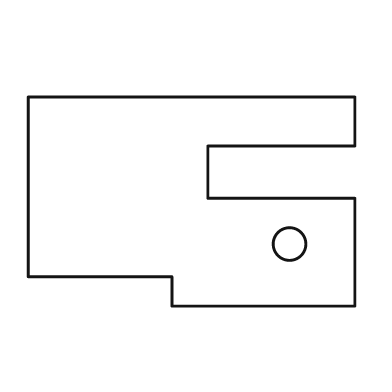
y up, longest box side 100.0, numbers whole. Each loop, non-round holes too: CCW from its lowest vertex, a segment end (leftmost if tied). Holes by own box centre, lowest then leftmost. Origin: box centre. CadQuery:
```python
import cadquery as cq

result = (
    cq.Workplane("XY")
    .moveTo(-6.0, -32.0)
    .lineTo(50.0, -32.0)
    .lineTo(50.0, 1.0)
    .lineTo(5.0, 1.0)
    .lineTo(5.0, 17.0)
    .lineTo(50.0, 17.0)
    .lineTo(50.0, 32.0)
    .lineTo(-50.0, 32.0)
    .lineTo(-50.0, -23.0)
    .lineTo(-6.0, -23.0)
    .close()
    .moveTo(30.0, -13.0)
    .circle(5.0)
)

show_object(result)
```